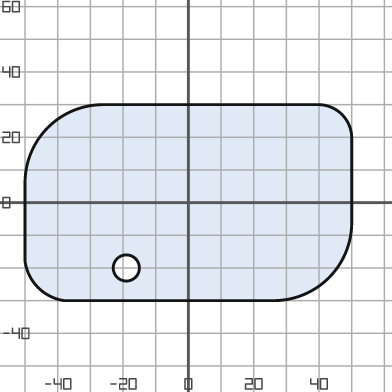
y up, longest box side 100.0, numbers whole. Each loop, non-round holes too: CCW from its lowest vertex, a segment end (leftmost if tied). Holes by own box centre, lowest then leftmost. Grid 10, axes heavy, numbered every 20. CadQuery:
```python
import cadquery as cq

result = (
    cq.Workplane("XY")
    .moveTo(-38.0, -30.0)
    .lineTo(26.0, -30.0)
    .threePointArc((43.0, -23.0), (50.0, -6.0))
    .lineTo(50.0, 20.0)
    .threePointArc((47.0, 27.0), (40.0, 30.0))
    .lineTo(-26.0, 30.0)
    .threePointArc((-43.0, 23.0), (-50.0, 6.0))
    .lineTo(-50.0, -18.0)
    .threePointArc((-46.0, -26.0), (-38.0, -30.0))
    .close()
    .moveTo(-19.0, -20.0)
    .circle(4.0)
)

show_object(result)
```